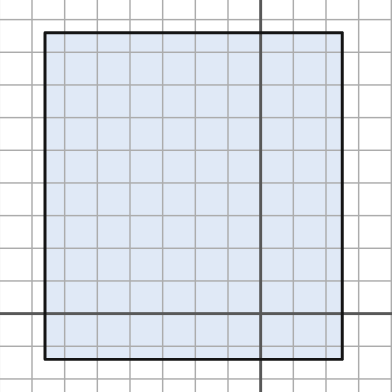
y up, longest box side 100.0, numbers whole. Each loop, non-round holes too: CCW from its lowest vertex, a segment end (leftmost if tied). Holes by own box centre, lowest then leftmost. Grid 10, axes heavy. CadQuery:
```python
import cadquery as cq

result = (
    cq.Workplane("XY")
    .moveTo(-66.0, -14.0)
    .lineTo(25.0, -14.0)
    .lineTo(25.0, 86.0)
    .lineTo(-66.0, 86.0)
    .close()
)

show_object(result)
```